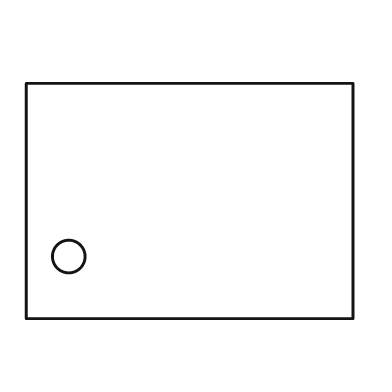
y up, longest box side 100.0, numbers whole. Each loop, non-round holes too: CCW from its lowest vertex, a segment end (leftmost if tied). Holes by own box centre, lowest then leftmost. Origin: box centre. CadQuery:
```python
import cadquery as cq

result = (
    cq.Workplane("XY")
    .moveTo(-50.0, -36.0)
    .lineTo(50.0, -36.0)
    .lineTo(50.0, 36.0)
    .lineTo(-50.0, 36.0)
    .close()
    .moveTo(-37.0, -17.0)
    .circle(5.0)
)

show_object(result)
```